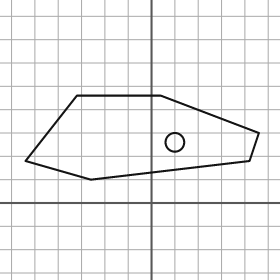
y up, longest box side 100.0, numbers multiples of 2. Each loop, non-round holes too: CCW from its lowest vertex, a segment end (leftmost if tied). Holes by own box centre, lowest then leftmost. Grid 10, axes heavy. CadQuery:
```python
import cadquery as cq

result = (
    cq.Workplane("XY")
    .moveTo(-26.0, 10.0)
    .lineTo(42.0, 18.0)
    .lineTo(46.0, 30.0)
    .lineTo(4.0, 46.0)
    .lineTo(-32.0, 46.0)
    .lineTo(-54.0, 18.0)
    .close()
    .moveTo(10.0, 26.0)
    .circle(4.0)
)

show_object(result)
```